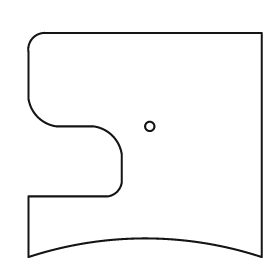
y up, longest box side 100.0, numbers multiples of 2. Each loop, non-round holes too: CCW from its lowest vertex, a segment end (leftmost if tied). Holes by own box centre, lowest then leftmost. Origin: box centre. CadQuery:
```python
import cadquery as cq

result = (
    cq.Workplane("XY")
    .moveTo(-50.0, -48.0)
    .threePointArc((0.0, -40.0), (50.0, -48.0))
    .lineTo(50.0, 48.0)
    .lineTo(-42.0, 48.0)
    .threePointArc((-48.0, 46.0), (-50.0, 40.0))
    .lineTo(-50.0, 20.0)
    .threePointArc((-46.0, 12.0), (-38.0, 8.0))
    .lineTo(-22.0, 8.0)
    .threePointArc((-14.0, 4.0), (-10.0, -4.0))
    .lineTo(-10.0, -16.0)
    .threePointArc((-12.0, -20.0), (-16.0, -22.0))
    .lineTo(-50.0, -22.0)
    .close()
    .moveTo(2.0, 8.0)
    .circle(2.0)
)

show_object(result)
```